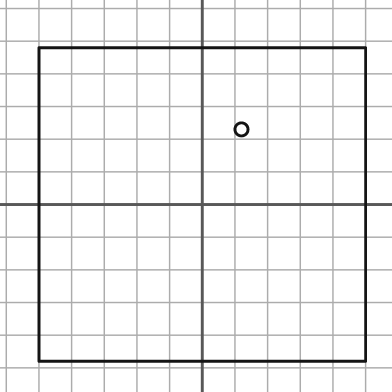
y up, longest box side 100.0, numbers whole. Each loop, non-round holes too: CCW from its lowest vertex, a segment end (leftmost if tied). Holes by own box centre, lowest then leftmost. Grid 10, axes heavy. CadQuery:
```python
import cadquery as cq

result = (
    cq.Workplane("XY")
    .moveTo(-50.0, -48.0)
    .lineTo(50.0, -48.0)
    .lineTo(50.0, 48.0)
    .lineTo(-50.0, 48.0)
    .close()
    .moveTo(12.0, 23.0)
    .circle(2.0)
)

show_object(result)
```